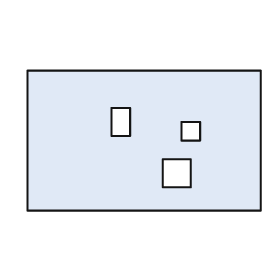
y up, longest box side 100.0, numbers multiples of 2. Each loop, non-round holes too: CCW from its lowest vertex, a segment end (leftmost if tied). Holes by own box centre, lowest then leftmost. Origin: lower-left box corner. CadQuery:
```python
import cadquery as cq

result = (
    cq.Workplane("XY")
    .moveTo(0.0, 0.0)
    .lineTo(100.0, 0.0)
    .lineTo(100.0, 60.0)
    .lineTo(0.0, 60.0)
    .close()
    .moveTo(58.0, 10.0)
    .lineTo(70.0, 10.0)
    .lineTo(70.0, 22.0)
    .lineTo(58.0, 22.0)
    .close()
    .moveTo(66.0, 30.0)
    .lineTo(74.0, 30.0)
    .lineTo(74.0, 38.0)
    .lineTo(66.0, 38.0)
    .close()
    .moveTo(36.0, 32.0)
    .lineTo(44.0, 32.0)
    .lineTo(44.0, 44.0)
    .lineTo(36.0, 44.0)
    .close()
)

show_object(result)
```